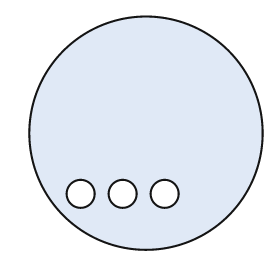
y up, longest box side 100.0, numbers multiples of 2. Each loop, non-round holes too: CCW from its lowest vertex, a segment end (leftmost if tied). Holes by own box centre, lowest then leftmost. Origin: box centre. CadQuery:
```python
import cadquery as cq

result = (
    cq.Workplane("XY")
    .moveTo(0.0, 0.0)
    .circle(50.0)
    .moveTo(-28.0, -26.0)
    .circle(6.0)
    .moveTo(-10.0, -26.0)
    .circle(6.0)
    .moveTo(8.0, -26.0)
    .circle(6.0)
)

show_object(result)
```